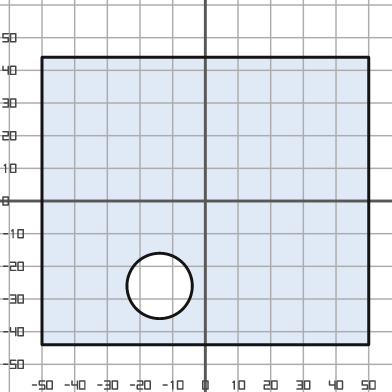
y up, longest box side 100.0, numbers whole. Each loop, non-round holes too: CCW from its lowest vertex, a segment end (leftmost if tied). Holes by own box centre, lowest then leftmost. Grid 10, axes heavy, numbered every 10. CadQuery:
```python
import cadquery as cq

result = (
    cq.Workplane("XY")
    .moveTo(-50.0, -44.0)
    .lineTo(50.0, -44.0)
    .lineTo(50.0, 44.0)
    .lineTo(-50.0, 44.0)
    .close()
    .moveTo(-14.0, -26.0)
    .circle(10.0)
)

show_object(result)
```